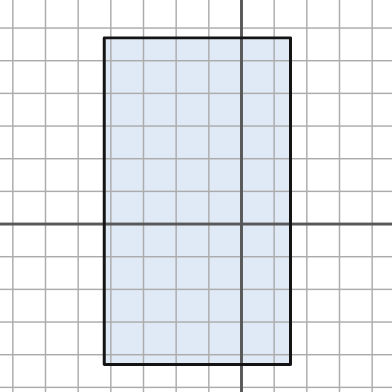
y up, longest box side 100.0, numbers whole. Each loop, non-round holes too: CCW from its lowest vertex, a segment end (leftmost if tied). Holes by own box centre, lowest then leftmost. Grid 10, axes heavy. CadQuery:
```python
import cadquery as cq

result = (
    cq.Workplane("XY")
    .moveTo(-42.0, -43.0)
    .lineTo(15.0, -43.0)
    .lineTo(15.0, 57.0)
    .lineTo(-42.0, 57.0)
    .close()
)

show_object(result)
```